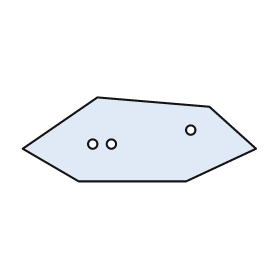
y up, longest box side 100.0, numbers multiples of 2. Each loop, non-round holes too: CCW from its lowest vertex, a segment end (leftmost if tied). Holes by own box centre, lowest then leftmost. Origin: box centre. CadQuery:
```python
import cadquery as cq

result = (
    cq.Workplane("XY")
    .moveTo(-26.0, -18.0)
    .lineTo(20.0, -18.0)
    .lineTo(50.0, -4.0)
    .lineTo(30.0, 14.0)
    .lineTo(-18.0, 18.0)
    .lineTo(-50.0, -4.0)
    .close()
    .moveTo(-20.0, -2.0)
    .circle(2.0)
    .moveTo(-12.0, -2.0)
    .circle(2.0)
    .moveTo(22.0, 4.0)
    .circle(2.0)
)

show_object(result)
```